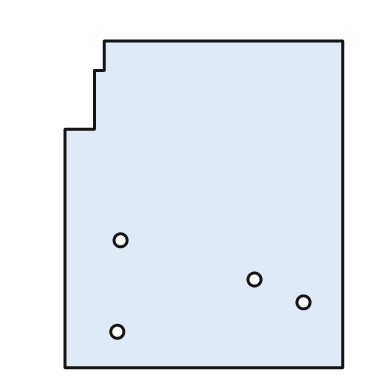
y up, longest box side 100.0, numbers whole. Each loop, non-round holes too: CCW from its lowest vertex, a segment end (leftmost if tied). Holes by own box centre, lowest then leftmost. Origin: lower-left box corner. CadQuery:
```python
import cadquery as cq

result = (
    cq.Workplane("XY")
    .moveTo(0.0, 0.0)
    .lineTo(85.0, 0.0)
    .lineTo(85.0, 100.0)
    .lineTo(12.0, 100.0)
    .lineTo(12.0, 91.0)
    .lineTo(9.0, 91.0)
    .lineTo(9.0, 73.0)
    .lineTo(0.0, 73.0)
    .close()
    .moveTo(16.0, 11.0)
    .circle(2.0)
    .moveTo(73.0, 20.0)
    .circle(2.0)
    .moveTo(58.0, 27.0)
    .circle(2.0)
    .moveTo(17.0, 39.0)
    .circle(2.0)
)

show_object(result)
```